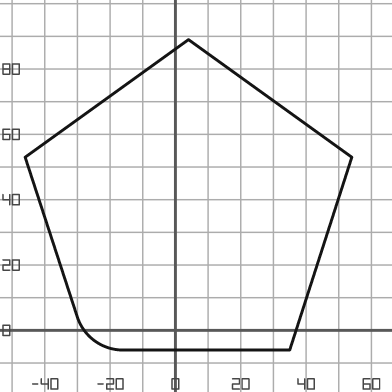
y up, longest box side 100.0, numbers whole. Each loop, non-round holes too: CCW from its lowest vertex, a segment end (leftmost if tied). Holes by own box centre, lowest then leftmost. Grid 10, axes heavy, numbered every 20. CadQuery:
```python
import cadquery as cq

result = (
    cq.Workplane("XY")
    .moveTo(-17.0, -6.0)
    .lineTo(35.0, -6.0)
    .lineTo(54.0, 53.0)
    .lineTo(4.0, 89.0)
    .lineTo(-46.0, 53.0)
    .lineTo(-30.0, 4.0)
    .threePointArc((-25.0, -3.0), (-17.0, -6.0))
    .close()
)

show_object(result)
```